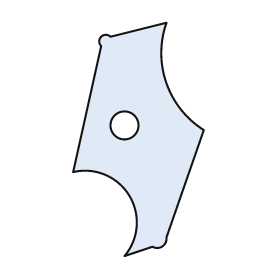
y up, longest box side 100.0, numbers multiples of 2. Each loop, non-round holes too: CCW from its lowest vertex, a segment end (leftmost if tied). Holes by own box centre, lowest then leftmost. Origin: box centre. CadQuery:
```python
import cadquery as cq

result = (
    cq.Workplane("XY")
    .moveTo(-6.0, -50.0)
    .lineTo(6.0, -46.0)
    .threePointArc((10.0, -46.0), (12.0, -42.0))
    .lineTo(28.0, 4.0)
    .threePointArc((12.0, 24.0), (12.0, 50.0))
    .lineTo(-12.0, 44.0)
    .threePointArc((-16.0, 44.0), (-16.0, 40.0))
    .lineTo(-28.0, -14.0)
    .threePointArc((-4.0, -24.0), (-6.0, -50.0))
    .close()
    .moveTo(-6.0, 6.0)
    .circle(6.0)
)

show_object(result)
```